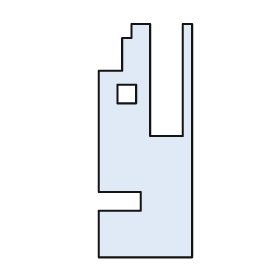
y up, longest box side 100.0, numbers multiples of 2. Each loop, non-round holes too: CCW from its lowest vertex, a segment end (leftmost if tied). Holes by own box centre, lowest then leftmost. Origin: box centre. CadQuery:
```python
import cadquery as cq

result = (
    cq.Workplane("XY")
    .moveTo(-20.0, -50.0)
    .lineTo(20.0, -50.0)
    .lineTo(20.0, 50.0)
    .lineTo(16.0, 50.0)
    .lineTo(16.0, 2.0)
    .lineTo(2.0, 2.0)
    .lineTo(2.0, 50.0)
    .lineTo(-6.0, 50.0)
    .lineTo(-6.0, 44.0)
    .lineTo(-10.0, 44.0)
    .lineTo(-10.0, 30.0)
    .lineTo(-20.0, 30.0)
    .lineTo(-20.0, -22.0)
    .lineTo(-2.0, -22.0)
    .lineTo(-2.0, -30.0)
    .lineTo(-20.0, -30.0)
    .close()
    .moveTo(-12.0, 16.0)
    .lineTo(-4.0, 16.0)
    .lineTo(-4.0, 24.0)
    .lineTo(-12.0, 24.0)
    .close()
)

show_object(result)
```